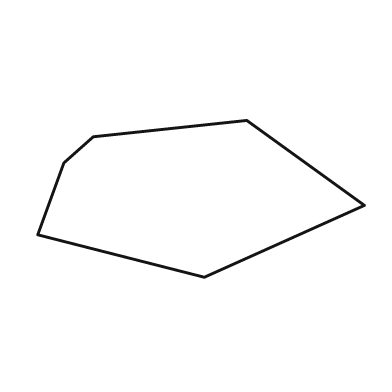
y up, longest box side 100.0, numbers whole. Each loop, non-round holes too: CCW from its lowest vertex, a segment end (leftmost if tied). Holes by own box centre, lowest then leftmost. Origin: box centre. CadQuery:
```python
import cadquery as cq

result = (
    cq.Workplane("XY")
    .moveTo(1.0, -24.0)
    .lineTo(50.0, -2.0)
    .lineTo(14.0, 24.0)
    .lineTo(-33.0, 19.0)
    .lineTo(-42.0, 11.0)
    .lineTo(-50.0, -11.0)
    .close()
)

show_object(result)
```